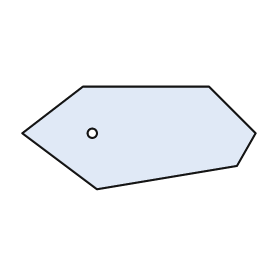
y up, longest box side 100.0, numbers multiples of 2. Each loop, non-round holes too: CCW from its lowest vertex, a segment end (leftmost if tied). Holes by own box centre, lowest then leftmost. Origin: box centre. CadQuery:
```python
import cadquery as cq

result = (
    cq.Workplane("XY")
    .moveTo(-18.0, -22.0)
    .lineTo(42.0, -12.0)
    .lineTo(50.0, 2.0)
    .lineTo(30.0, 22.0)
    .lineTo(-24.0, 22.0)
    .lineTo(-50.0, 2.0)
    .close()
    .moveTo(-20.0, 2.0)
    .circle(2.0)
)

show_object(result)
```